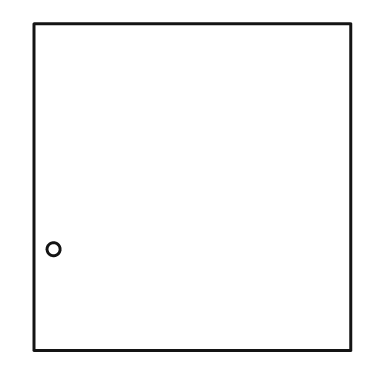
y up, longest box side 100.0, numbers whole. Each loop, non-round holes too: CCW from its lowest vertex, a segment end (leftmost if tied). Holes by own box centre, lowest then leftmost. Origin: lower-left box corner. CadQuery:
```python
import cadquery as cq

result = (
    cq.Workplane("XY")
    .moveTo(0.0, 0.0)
    .lineTo(97.0, 0.0)
    .lineTo(97.0, 100.0)
    .lineTo(0.0, 100.0)
    .close()
    .moveTo(6.0, 31.0)
    .circle(2.0)
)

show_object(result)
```